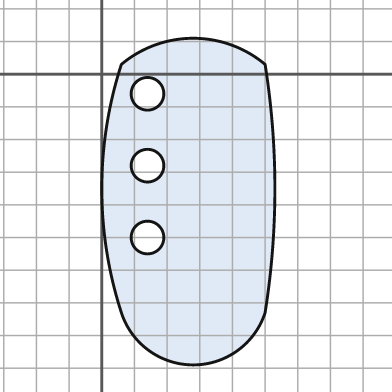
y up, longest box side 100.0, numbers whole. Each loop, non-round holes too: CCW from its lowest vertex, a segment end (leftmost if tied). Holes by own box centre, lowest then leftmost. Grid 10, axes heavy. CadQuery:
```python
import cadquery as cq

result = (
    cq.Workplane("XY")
    .moveTo(6.0, -73.0)
    .threePointArc((28.0, -89.0), (50.0, -73.0))
    .threePointArc((53.0, -35.0), (50.0, 3.0))
    .threePointArc((28.0, 11.0), (6.0, 3.0))
    .threePointArc((0.0, -35.0), (6.0, -73.0))
    .close()
    .moveTo(14.0, -50.0)
    .circle(5.0)
    .moveTo(14.0, -28.0)
    .circle(5.0)
    .moveTo(14.0, -6.0)
    .circle(5.0)
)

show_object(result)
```